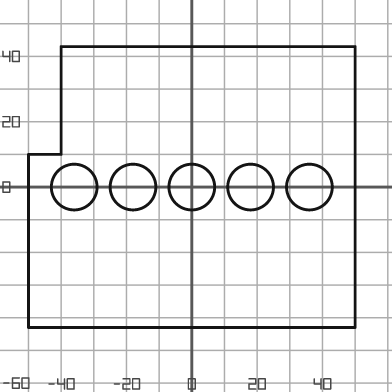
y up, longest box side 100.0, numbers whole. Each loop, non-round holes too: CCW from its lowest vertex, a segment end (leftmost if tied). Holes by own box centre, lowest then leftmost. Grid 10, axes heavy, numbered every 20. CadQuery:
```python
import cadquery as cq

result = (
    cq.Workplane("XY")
    .moveTo(-50.0, -43.0)
    .lineTo(50.0, -43.0)
    .lineTo(50.0, 43.0)
    .lineTo(-40.0, 43.0)
    .lineTo(-40.0, 10.0)
    .lineTo(-50.0, 10.0)
    .close()
    .moveTo(-36.0, 0.0)
    .circle(7.0)
    .moveTo(-18.0, 0.0)
    .circle(7.0)
    .moveTo(0.0, 0.0)
    .circle(7.0)
    .moveTo(18.0, 0.0)
    .circle(7.0)
    .moveTo(36.0, 0.0)
    .circle(7.0)
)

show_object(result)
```